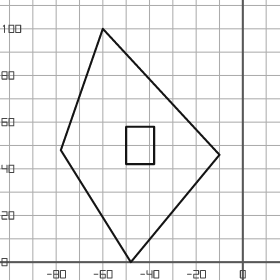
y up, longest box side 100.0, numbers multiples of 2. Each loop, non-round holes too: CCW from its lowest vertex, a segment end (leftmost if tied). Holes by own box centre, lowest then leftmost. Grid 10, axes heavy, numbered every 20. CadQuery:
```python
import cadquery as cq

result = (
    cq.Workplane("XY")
    .moveTo(-48.0, 0.0)
    .lineTo(-10.0, 46.0)
    .lineTo(-60.0, 100.0)
    .lineTo(-78.0, 48.0)
    .close()
    .moveTo(-50.0, 42.0)
    .lineTo(-38.0, 42.0)
    .lineTo(-38.0, 58.0)
    .lineTo(-50.0, 58.0)
    .close()
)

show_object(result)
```